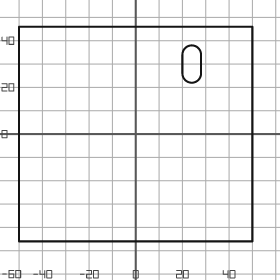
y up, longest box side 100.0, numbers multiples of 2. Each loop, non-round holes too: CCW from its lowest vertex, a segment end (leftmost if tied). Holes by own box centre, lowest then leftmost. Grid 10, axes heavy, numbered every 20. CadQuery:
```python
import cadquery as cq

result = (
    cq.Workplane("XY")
    .moveTo(-50.0, -46.0)
    .lineTo(50.0, -46.0)
    .lineTo(50.0, 46.0)
    .lineTo(-50.0, 46.0)
    .close()
    .moveTo(20.0, 26.0)
    .threePointArc((24.0, 22.0), (28.0, 26.0))
    .lineTo(28.0, 34.0)
    .threePointArc((24.0, 38.0), (20.0, 34.0))
    .close()
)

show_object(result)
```